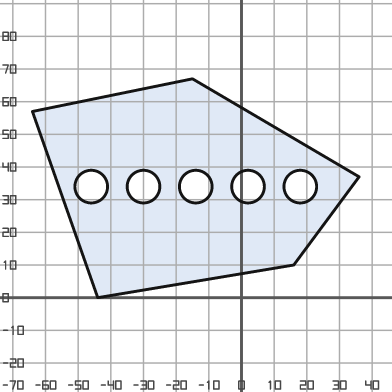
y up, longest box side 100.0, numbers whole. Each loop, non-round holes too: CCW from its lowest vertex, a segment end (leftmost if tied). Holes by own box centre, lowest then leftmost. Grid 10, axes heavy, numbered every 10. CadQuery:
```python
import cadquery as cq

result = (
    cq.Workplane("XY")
    .moveTo(-44.0, 0.0)
    .lineTo(16.0, 10.0)
    .lineTo(36.0, 37.0)
    .lineTo(-15.0, 67.0)
    .lineTo(-64.0, 57.0)
    .close()
    .moveTo(-46.0, 34.0)
    .circle(5.0)
    .moveTo(-30.0, 34.0)
    .circle(5.0)
    .moveTo(-14.0, 34.0)
    .circle(5.0)
    .moveTo(2.0, 34.0)
    .circle(5.0)
    .moveTo(18.0, 34.0)
    .circle(5.0)
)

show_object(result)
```